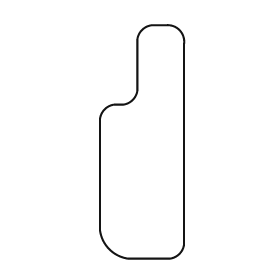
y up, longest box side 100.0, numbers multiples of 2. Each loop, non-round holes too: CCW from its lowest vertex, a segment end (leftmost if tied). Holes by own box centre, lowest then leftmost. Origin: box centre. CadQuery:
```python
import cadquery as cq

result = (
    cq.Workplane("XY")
    .moveTo(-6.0, -50.0)
    .lineTo(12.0, -50.0)
    .threePointArc((16.0, -48.0), (18.0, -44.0))
    .lineTo(18.0, 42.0)
    .threePointArc((16.0, 48.0), (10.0, 50.0))
    .lineTo(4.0, 50.0)
    .threePointArc((0.0, 48.0), (-2.0, 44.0))
    .lineTo(-2.0, 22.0)
    .threePointArc((-4.0, 18.0), (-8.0, 16.0))
    .lineTo(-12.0, 16.0)
    .threePointArc((-16.0, 14.0), (-18.0, 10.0))
    .lineTo(-18.0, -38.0)
    .threePointArc((-14.0, -46.0), (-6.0, -50.0))
    .close()
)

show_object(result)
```